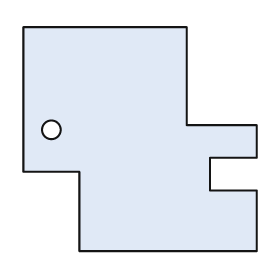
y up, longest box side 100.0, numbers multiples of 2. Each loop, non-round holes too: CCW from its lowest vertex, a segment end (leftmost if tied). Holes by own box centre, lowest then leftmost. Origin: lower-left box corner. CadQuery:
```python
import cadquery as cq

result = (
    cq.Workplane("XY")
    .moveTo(24.0, 0.0)
    .lineTo(100.0, 0.0)
    .lineTo(100.0, 26.0)
    .lineTo(80.0, 26.0)
    .lineTo(80.0, 40.0)
    .lineTo(100.0, 40.0)
    .lineTo(100.0, 54.0)
    .lineTo(70.0, 54.0)
    .lineTo(70.0, 96.0)
    .lineTo(0.0, 96.0)
    .lineTo(0.0, 34.0)
    .lineTo(24.0, 34.0)
    .close()
    .moveTo(12.0, 52.0)
    .circle(4.0)
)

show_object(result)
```